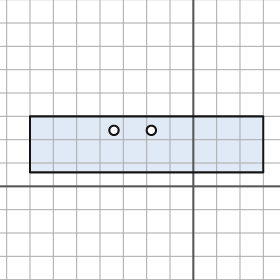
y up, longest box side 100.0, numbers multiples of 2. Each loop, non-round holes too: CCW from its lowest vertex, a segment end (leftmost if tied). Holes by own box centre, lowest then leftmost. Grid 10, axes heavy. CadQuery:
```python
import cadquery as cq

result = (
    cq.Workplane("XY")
    .moveTo(-70.0, 6.0)
    .lineTo(30.0, 6.0)
    .lineTo(30.0, 30.0)
    .lineTo(-70.0, 30.0)
    .close()
    .moveTo(-34.0, 24.0)
    .circle(2.0)
    .moveTo(-18.0, 24.0)
    .circle(2.0)
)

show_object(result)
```